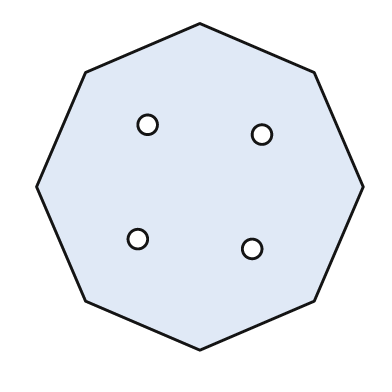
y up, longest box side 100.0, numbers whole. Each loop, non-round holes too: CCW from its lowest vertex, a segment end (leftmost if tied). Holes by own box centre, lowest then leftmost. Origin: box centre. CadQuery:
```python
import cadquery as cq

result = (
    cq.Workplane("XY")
    .moveTo(0.0, -50.0)
    .lineTo(35.0, -35.0)
    .lineTo(50.0, 0.0)
    .lineTo(35.0, 35.0)
    .lineTo(0.0, 50.0)
    .lineTo(-35.0, 35.0)
    .lineTo(-50.0, 0.0)
    .lineTo(-35.0, -35.0)
    .close()
    .moveTo(16.0, -19.0)
    .circle(3.0)
    .moveTo(-19.0, -16.0)
    .circle(3.0)
    .moveTo(19.0, 16.0)
    .circle(3.0)
    .moveTo(-16.0, 19.0)
    .circle(3.0)
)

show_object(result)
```